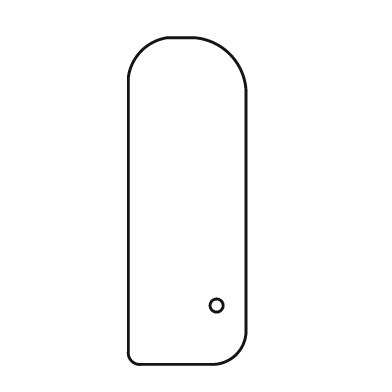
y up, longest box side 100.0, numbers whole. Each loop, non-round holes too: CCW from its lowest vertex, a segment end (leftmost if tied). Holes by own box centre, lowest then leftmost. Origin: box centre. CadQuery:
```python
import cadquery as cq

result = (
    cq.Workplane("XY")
    .moveTo(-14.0, -50.0)
    .lineTo(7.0, -50.0)
    .threePointArc((15.0, -47.0), (18.0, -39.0))
    .lineTo(18.0, 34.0)
    .threePointArc((13.0, 45.0), (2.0, 50.0))
    .lineTo(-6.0, 50.0)
    .threePointArc((-14.0, 46.0), (-18.0, 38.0))
    .lineTo(-18.0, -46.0)
    .threePointArc((-17.0, -49.0), (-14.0, -50.0))
    .close()
    .moveTo(9.0, -32.0)
    .circle(2.0)
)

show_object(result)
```